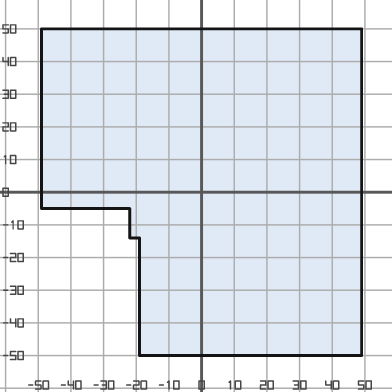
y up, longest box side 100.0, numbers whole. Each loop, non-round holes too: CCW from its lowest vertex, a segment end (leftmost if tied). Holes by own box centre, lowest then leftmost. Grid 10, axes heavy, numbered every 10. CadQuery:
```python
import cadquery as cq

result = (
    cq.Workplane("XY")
    .moveTo(-19.0, -50.0)
    .lineTo(49.0, -50.0)
    .lineTo(49.0, 50.0)
    .lineTo(-49.0, 50.0)
    .lineTo(-49.0, -5.0)
    .lineTo(-22.0, -5.0)
    .lineTo(-22.0, -14.0)
    .lineTo(-19.0, -14.0)
    .close()
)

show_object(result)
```